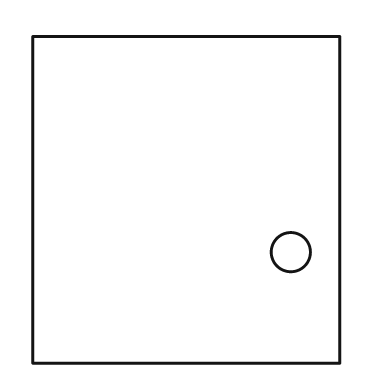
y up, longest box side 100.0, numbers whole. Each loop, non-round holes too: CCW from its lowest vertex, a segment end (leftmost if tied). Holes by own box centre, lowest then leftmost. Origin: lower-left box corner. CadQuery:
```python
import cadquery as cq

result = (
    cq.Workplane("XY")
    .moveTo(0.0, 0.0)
    .lineTo(94.0, 0.0)
    .lineTo(94.0, 100.0)
    .lineTo(0.0, 100.0)
    .close()
    .moveTo(79.0, 34.0)
    .circle(6.0)
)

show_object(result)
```